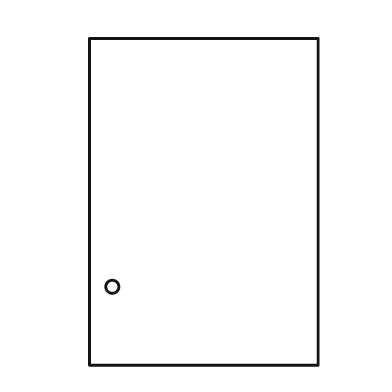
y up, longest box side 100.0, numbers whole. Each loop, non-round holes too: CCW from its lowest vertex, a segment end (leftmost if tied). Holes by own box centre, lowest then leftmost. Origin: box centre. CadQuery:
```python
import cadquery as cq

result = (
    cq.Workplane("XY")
    .moveTo(-35.0, -50.0)
    .lineTo(35.0, -50.0)
    .lineTo(35.0, 50.0)
    .lineTo(-35.0, 50.0)
    .close()
    .moveTo(-28.0, -26.0)
    .circle(2.0)
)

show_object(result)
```